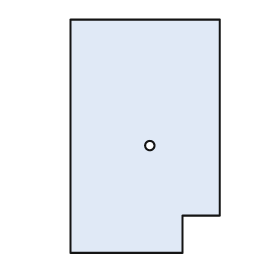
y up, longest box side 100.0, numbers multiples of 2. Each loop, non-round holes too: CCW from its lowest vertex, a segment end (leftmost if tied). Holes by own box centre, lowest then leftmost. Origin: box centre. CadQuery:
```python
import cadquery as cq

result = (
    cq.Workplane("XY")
    .moveTo(-32.0, -50.0)
    .lineTo(16.0, -50.0)
    .lineTo(16.0, -34.0)
    .lineTo(32.0, -34.0)
    .lineTo(32.0, 50.0)
    .lineTo(-32.0, 50.0)
    .close()
    .moveTo(2.0, -4.0)
    .circle(2.0)
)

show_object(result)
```